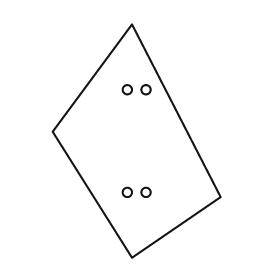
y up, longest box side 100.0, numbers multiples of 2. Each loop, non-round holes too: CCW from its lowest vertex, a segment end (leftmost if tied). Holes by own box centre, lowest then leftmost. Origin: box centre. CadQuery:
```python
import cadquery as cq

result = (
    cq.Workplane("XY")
    .moveTo(-2.0, -50.0)
    .lineTo(36.0, -24.0)
    .lineTo(-2.0, 50.0)
    .lineTo(-36.0, 4.0)
    .close()
    .moveTo(-4.0, -22.0)
    .circle(2.0)
    .moveTo(4.0, -22.0)
    .circle(2.0)
    .moveTo(-4.0, 22.0)
    .circle(2.0)
    .moveTo(4.0, 22.0)
    .circle(2.0)
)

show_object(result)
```